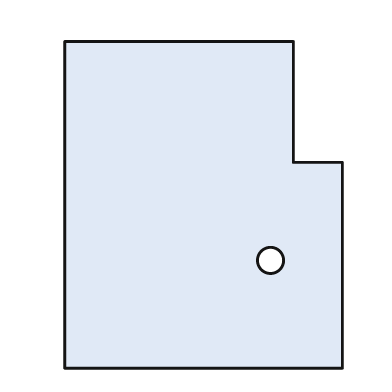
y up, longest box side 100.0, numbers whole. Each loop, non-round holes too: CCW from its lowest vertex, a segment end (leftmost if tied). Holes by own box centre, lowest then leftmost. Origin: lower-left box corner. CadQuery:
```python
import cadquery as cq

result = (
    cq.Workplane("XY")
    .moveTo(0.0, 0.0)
    .lineTo(85.0, 0.0)
    .lineTo(85.0, 63.0)
    .lineTo(70.0, 63.0)
    .lineTo(70.0, 100.0)
    .lineTo(0.0, 100.0)
    .close()
    .moveTo(63.0, 33.0)
    .circle(4.0)
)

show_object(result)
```